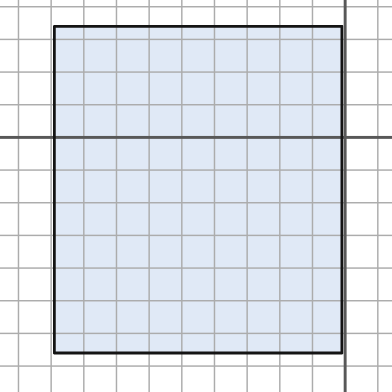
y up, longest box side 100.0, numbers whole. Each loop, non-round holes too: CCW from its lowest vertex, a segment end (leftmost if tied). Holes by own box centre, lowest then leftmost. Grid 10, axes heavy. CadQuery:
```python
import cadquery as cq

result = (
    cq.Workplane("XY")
    .moveTo(-89.0, -66.0)
    .lineTo(-1.0, -66.0)
    .lineTo(-1.0, 34.0)
    .lineTo(-89.0, 34.0)
    .close()
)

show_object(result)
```